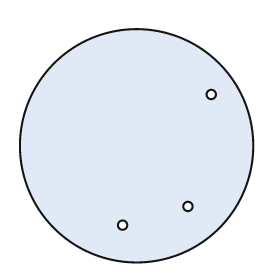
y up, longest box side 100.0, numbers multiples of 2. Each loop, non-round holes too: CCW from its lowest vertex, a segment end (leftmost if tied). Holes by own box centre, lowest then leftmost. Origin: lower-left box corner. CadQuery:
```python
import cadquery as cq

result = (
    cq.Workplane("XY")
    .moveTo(50.0, 50.0)
    .circle(50.0)
    .moveTo(44.0, 16.0)
    .circle(2.0)
    .moveTo(72.0, 24.0)
    .circle(2.0)
    .moveTo(82.0, 72.0)
    .circle(2.0)
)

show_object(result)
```